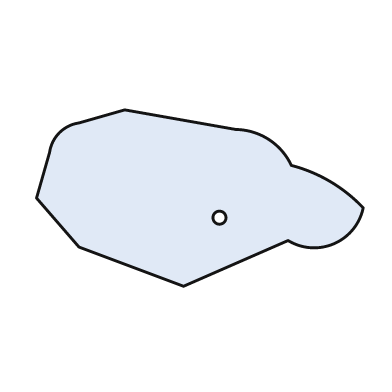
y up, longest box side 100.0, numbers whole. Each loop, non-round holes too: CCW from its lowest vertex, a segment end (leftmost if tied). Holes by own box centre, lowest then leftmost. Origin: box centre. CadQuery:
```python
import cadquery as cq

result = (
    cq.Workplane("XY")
    .moveTo(-5.0, -27.0)
    .lineTo(27.0, -13.0)
    .threePointArc((41.0, -14.0), (50.0, -3.0))
    .threePointArc((40.0, 5.0), (28.0, 10.0))
    .threePointArc((21.0, 18.0), (11.0, 21.0))
    .lineTo(-23.0, 27.0)
    .lineTo(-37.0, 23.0)
    .threePointArc((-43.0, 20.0), (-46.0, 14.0))
    .lineTo(-50.0, 0.0)
    .lineTo(-37.0, -15.0)
    .close()
    .moveTo(6.0, -6.0)
    .circle(2.0)
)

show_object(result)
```